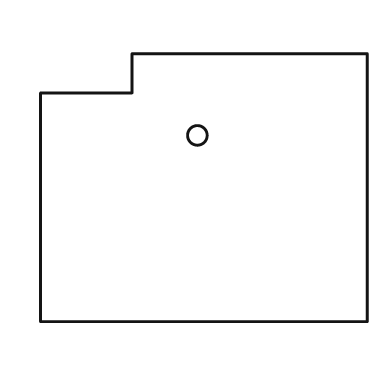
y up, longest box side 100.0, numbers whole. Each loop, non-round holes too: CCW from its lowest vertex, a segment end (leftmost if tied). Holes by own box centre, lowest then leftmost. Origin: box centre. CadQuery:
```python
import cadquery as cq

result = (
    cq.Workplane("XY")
    .moveTo(-50.0, -41.0)
    .lineTo(50.0, -41.0)
    .lineTo(50.0, 41.0)
    .lineTo(-22.0, 41.0)
    .lineTo(-22.0, 29.0)
    .lineTo(-50.0, 29.0)
    .close()
    .moveTo(-2.0, 16.0)
    .circle(3.0)
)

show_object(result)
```